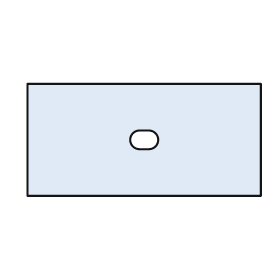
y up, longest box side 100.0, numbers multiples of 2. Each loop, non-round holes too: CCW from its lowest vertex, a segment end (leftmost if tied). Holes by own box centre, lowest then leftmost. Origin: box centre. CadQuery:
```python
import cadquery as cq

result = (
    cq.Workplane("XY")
    .moveTo(-50.0, -24.0)
    .lineTo(50.0, -24.0)
    .lineTo(50.0, 24.0)
    .lineTo(-50.0, 24.0)
    .close()
    .moveTo(-2.0, -4.0)
    .lineTo(2.0, -4.0)
    .threePointArc((6.0, 0.0), (2.0, 4.0))
    .lineTo(-2.0, 4.0)
    .threePointArc((-6.0, 0.0), (-2.0, -4.0))
    .close()
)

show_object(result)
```